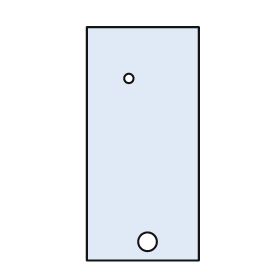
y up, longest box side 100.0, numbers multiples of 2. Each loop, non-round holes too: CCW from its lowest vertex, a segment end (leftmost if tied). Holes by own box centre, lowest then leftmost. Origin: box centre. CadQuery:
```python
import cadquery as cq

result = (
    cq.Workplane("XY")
    .moveTo(-24.0, -50.0)
    .lineTo(24.0, -50.0)
    .lineTo(24.0, 50.0)
    .lineTo(-24.0, 50.0)
    .close()
    .moveTo(2.0, -42.0)
    .circle(4.0)
    .moveTo(-6.0, 28.0)
    .circle(2.0)
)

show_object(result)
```